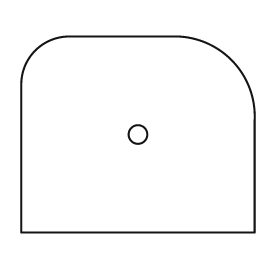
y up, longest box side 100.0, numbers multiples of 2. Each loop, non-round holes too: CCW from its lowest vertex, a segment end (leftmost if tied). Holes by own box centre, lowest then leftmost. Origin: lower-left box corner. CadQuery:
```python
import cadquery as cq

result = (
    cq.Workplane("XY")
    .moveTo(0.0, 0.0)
    .lineTo(100.0, 0.0)
    .lineTo(100.0, 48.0)
    .threePointArc((90.0, 74.0), (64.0, 84.0))
    .lineTo(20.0, 84.0)
    .threePointArc((6.0, 78.0), (0.0, 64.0))
    .close()
    .moveTo(50.0, 42.0)
    .circle(4.0)
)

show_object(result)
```